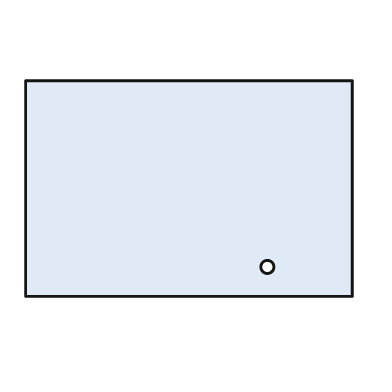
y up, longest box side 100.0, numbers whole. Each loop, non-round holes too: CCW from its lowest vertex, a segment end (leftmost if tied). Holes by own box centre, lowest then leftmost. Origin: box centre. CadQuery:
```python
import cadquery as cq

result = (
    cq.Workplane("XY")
    .moveTo(-50.0, -33.0)
    .lineTo(50.0, -33.0)
    .lineTo(50.0, 33.0)
    .lineTo(-50.0, 33.0)
    .close()
    .moveTo(24.0, -24.0)
    .circle(2.0)
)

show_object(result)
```